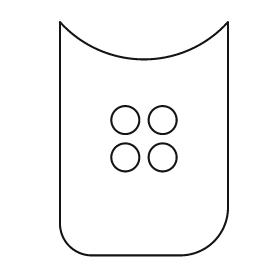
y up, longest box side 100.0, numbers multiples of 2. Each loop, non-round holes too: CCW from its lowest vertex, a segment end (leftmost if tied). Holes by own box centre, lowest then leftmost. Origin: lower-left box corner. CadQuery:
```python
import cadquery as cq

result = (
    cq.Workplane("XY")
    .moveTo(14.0, 0.0)
    .lineTo(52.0, 0.0)
    .threePointArc((66.0, 6.0), (72.0, 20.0))
    .lineTo(72.0, 100.0)
    .threePointArc((36.0, 84.0), (0.0, 100.0))
    .lineTo(0.0, 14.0)
    .threePointArc((4.0, 4.0), (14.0, 0.0))
    .close()
    .moveTo(28.0, 42.0)
    .circle(6.0)
    .moveTo(44.0, 42.0)
    .circle(6.0)
    .moveTo(28.0, 58.0)
    .circle(6.0)
    .moveTo(44.0, 58.0)
    .circle(6.0)
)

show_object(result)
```